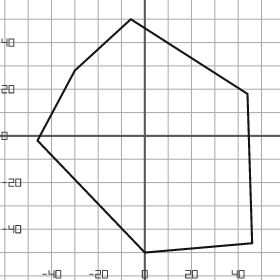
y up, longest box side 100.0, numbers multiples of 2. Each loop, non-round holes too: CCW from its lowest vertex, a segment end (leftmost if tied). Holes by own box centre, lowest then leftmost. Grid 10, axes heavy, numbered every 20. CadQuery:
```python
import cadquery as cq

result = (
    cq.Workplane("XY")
    .moveTo(0.0, -50.0)
    .lineTo(46.0, -46.0)
    .lineTo(44.0, 18.0)
    .lineTo(-6.0, 50.0)
    .lineTo(-30.0, 28.0)
    .lineTo(-46.0, -2.0)
    .close()
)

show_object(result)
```